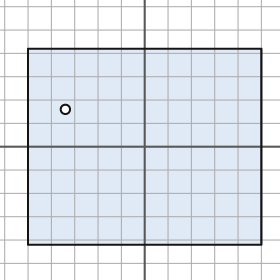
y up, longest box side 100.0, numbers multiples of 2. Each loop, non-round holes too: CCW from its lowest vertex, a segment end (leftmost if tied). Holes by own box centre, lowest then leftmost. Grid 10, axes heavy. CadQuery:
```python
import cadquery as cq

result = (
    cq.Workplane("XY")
    .moveTo(-50.0, -42.0)
    .lineTo(50.0, -42.0)
    .lineTo(50.0, 42.0)
    .lineTo(-50.0, 42.0)
    .close()
    .moveTo(-34.0, 16.0)
    .circle(2.0)
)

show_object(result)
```